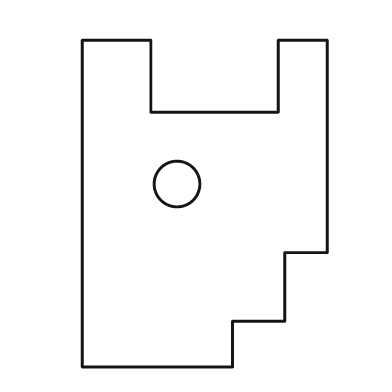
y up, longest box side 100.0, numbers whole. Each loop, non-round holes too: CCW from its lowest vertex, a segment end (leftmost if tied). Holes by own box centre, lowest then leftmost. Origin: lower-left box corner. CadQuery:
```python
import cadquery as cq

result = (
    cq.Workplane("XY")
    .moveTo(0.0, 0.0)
    .lineTo(46.0, 0.0)
    .lineTo(46.0, 14.0)
    .lineTo(62.0, 14.0)
    .lineTo(62.0, 35.0)
    .lineTo(75.0, 35.0)
    .lineTo(75.0, 100.0)
    .lineTo(60.0, 100.0)
    .lineTo(60.0, 78.0)
    .lineTo(21.0, 78.0)
    .lineTo(21.0, 100.0)
    .lineTo(0.0, 100.0)
    .close()
    .moveTo(29.0, 56.0)
    .circle(7.0)
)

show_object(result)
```